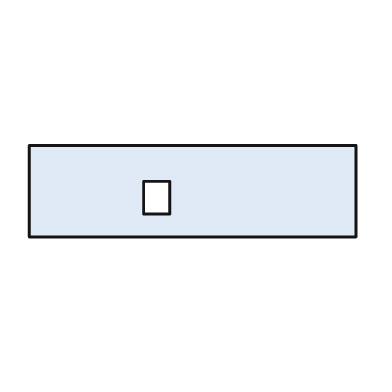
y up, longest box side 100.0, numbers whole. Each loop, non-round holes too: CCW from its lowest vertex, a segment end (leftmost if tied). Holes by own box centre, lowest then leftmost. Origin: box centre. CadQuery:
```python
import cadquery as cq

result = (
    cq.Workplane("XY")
    .moveTo(-50.0, -14.0)
    .lineTo(50.0, -14.0)
    .lineTo(50.0, 14.0)
    .lineTo(-50.0, 14.0)
    .close()
    .moveTo(-15.0, -7.0)
    .lineTo(-7.0, -7.0)
    .lineTo(-7.0, 3.0)
    .lineTo(-15.0, 3.0)
    .close()
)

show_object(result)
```